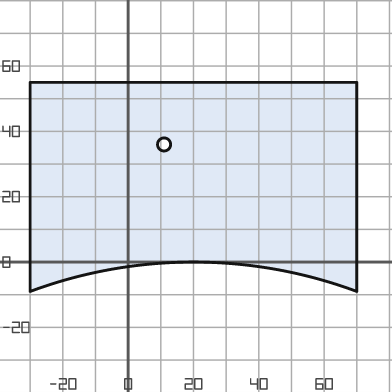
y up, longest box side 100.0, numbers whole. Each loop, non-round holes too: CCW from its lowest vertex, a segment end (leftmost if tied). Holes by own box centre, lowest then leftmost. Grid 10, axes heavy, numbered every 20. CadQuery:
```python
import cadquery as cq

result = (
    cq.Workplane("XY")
    .moveTo(-30.0, -9.0)
    .threePointArc((20.0, 0.0), (70.0, -9.0))
    .lineTo(70.0, 55.0)
    .lineTo(-30.0, 55.0)
    .close()
    .moveTo(11.0, 36.0)
    .circle(2.0)
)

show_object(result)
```